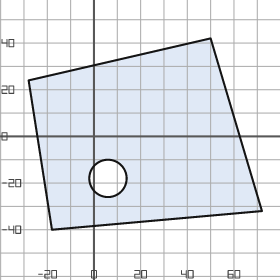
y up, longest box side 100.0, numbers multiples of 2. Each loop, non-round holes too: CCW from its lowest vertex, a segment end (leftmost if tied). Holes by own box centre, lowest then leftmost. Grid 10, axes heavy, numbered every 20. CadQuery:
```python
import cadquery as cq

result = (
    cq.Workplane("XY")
    .moveTo(-18.0, -40.0)
    .lineTo(72.0, -32.0)
    .lineTo(50.0, 42.0)
    .lineTo(-28.0, 24.0)
    .close()
    .moveTo(6.0, -18.0)
    .circle(8.0)
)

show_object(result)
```